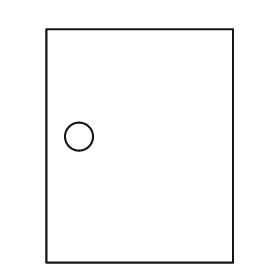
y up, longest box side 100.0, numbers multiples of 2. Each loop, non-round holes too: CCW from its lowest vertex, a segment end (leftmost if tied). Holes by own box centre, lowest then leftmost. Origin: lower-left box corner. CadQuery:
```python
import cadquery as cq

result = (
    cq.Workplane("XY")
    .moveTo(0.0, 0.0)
    .lineTo(80.0, 0.0)
    .lineTo(80.0, 100.0)
    .lineTo(0.0, 100.0)
    .close()
    .moveTo(14.0, 54.0)
    .circle(6.0)
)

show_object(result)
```